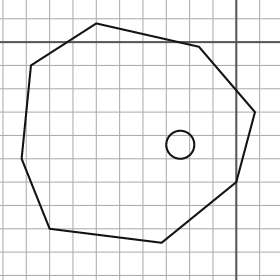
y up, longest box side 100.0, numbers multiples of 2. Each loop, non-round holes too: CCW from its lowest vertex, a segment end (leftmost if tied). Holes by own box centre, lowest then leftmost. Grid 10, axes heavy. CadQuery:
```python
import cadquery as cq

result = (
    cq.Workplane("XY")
    .moveTo(-32.0, -86.0)
    .lineTo(0.0, -60.0)
    .lineTo(8.0, -30.0)
    .lineTo(-16.0, -2.0)
    .lineTo(-60.0, 8.0)
    .lineTo(-88.0, -10.0)
    .lineTo(-92.0, -50.0)
    .lineTo(-80.0, -80.0)
    .close()
    .moveTo(-24.0, -44.0)
    .circle(6.0)
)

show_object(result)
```